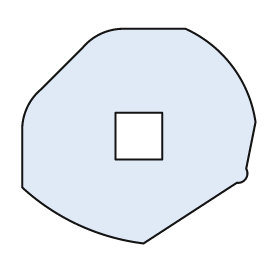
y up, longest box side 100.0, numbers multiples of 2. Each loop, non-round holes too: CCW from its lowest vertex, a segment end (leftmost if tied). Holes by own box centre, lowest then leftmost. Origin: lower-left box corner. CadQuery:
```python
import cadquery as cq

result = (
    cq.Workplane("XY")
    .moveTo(52.0, 0.0)
    .lineTo(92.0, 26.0)
    .threePointArc((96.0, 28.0), (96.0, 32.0))
    .lineTo(100.0, 52.0)
    .threePointArc((90.0, 76.0), (70.0, 92.0))
    .lineTo(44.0, 92.0)
    .threePointArc((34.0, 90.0), (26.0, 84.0))
    .lineTo(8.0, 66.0)
    .threePointArc((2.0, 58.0), (0.0, 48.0))
    .lineTo(0.0, 24.0)
    .threePointArc((24.0, 8.0), (52.0, 0.0))
    .close()
    .moveTo(40.0, 36.0)
    .lineTo(60.0, 36.0)
    .lineTo(60.0, 56.0)
    .lineTo(40.0, 56.0)
    .close()
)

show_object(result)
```